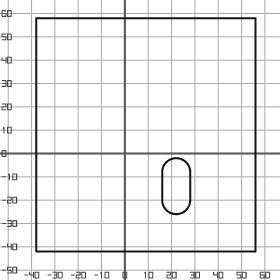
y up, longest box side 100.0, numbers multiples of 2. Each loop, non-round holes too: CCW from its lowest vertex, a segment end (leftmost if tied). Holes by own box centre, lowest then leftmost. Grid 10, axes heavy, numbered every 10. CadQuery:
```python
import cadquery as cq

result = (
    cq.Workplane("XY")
    .moveTo(-38.0, -42.0)
    .lineTo(56.0, -42.0)
    .lineTo(56.0, 58.0)
    .lineTo(-38.0, 58.0)
    .close()
    .moveTo(16.0, -20.0)
    .threePointArc((22.0, -26.0), (28.0, -20.0))
    .lineTo(28.0, -8.0)
    .threePointArc((22.0, -2.0), (16.0, -8.0))
    .close()
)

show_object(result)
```